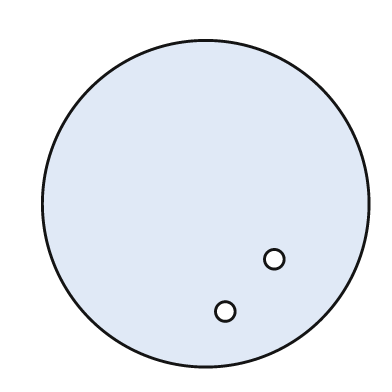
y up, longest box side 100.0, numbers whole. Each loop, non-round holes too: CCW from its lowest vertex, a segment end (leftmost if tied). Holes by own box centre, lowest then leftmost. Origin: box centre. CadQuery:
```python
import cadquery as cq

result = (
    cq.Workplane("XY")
    .moveTo(0.0, 0.0)
    .circle(50.0)
    .moveTo(6.0, -33.0)
    .circle(3.0)
    .moveTo(21.0, -17.0)
    .circle(3.0)
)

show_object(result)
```